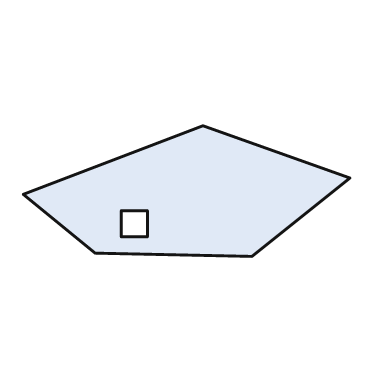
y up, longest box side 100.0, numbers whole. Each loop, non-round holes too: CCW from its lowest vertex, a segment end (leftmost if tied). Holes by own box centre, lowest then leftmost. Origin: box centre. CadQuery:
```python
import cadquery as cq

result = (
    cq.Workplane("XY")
    .moveTo(20.0, -20.0)
    .lineTo(50.0, 4.0)
    .lineTo(5.0, 20.0)
    .lineTo(-50.0, -1.0)
    .lineTo(-28.0, -19.0)
    .close()
    .moveTo(-20.0, -14.0)
    .lineTo(-12.0, -14.0)
    .lineTo(-12.0, -6.0)
    .lineTo(-20.0, -6.0)
    .close()
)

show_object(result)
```